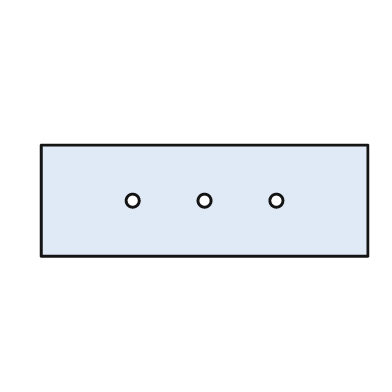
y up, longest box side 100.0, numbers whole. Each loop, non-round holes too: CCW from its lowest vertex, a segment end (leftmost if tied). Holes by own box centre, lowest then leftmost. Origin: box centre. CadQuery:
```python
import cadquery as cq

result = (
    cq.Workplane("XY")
    .moveTo(-50.0, -17.0)
    .lineTo(50.0, -17.0)
    .lineTo(50.0, 17.0)
    .lineTo(-50.0, 17.0)
    .close()
    .moveTo(-22.0, 0.0)
    .circle(2.0)
    .moveTo(0.0, 0.0)
    .circle(2.0)
    .moveTo(22.0, 0.0)
    .circle(2.0)
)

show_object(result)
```